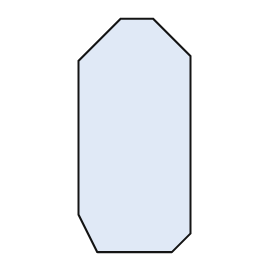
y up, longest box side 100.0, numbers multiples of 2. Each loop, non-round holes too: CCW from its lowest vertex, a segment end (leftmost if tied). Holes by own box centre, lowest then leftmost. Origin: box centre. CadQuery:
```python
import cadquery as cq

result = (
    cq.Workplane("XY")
    .moveTo(-16.0, -50.0)
    .lineTo(16.0, -50.0)
    .lineTo(24.0, -42.0)
    .lineTo(24.0, 34.0)
    .lineTo(8.0, 50.0)
    .lineTo(-6.0, 50.0)
    .lineTo(-24.0, 32.0)
    .lineTo(-24.0, -34.0)
    .close()
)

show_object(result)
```